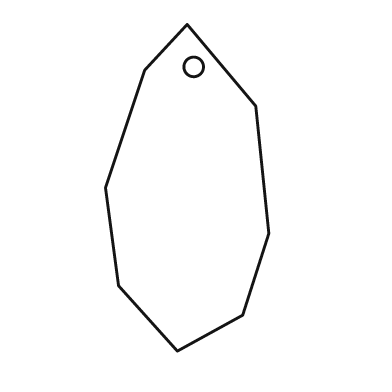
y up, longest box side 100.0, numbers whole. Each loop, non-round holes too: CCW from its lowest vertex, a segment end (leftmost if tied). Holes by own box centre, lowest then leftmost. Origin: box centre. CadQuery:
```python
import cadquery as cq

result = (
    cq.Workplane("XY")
    .moveTo(-3.0, -50.0)
    .lineTo(17.0, -39.0)
    .lineTo(25.0, -14.0)
    .lineTo(21.0, 25.0)
    .lineTo(0.0, 50.0)
    .lineTo(-13.0, 36.0)
    .lineTo(-25.0, 0.0)
    .lineTo(-21.0, -30.0)
    .close()
    .moveTo(2.0, 37.0)
    .circle(3.0)
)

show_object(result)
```